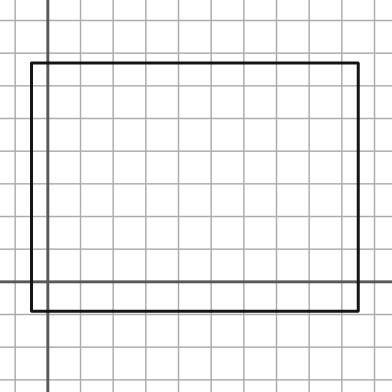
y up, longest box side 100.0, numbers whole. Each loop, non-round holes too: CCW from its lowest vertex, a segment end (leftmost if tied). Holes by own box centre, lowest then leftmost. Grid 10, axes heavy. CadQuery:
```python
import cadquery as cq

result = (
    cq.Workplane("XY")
    .moveTo(-5.0, -9.0)
    .lineTo(95.0, -9.0)
    .lineTo(95.0, 67.0)
    .lineTo(-5.0, 67.0)
    .close()
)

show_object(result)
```